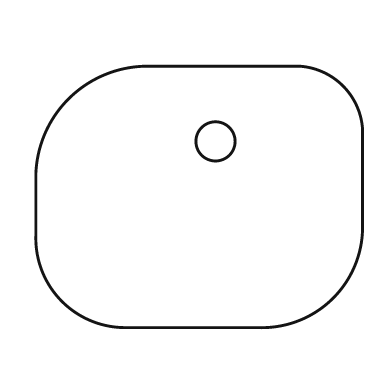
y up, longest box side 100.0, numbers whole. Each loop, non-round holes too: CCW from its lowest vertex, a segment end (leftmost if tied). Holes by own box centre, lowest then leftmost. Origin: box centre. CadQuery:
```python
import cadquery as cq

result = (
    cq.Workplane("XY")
    .moveTo(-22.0, -40.0)
    .lineTo(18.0, -40.0)
    .threePointArc((41.0, -31.0), (50.0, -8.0))
    .lineTo(50.0, 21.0)
    .threePointArc((44.0, 34.0), (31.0, 40.0))
    .lineTo(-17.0, 40.0)
    .threePointArc((-40.0, 30.0), (-50.0, 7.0))
    .lineTo(-50.0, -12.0)
    .threePointArc((-42.0, -32.0), (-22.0, -40.0))
    .close()
    .moveTo(5.0, 17.0)
    .circle(6.0)
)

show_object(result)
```